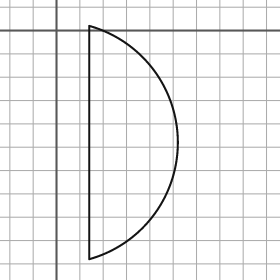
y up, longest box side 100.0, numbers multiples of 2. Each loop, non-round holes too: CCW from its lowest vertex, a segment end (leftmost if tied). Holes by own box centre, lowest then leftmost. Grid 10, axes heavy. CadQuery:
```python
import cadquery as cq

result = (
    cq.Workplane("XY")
    .moveTo(14.0, -98.0)
    .threePointArc((52.0, -48.0), (14.0, 2.0))
    .close()
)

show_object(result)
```